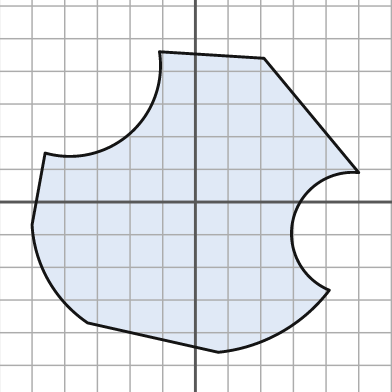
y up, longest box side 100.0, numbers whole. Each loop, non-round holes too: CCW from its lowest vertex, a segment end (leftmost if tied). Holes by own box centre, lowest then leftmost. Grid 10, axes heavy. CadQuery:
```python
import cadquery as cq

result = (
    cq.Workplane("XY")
    .moveTo(7.0, -46.0)
    .threePointArc((26.0, -40.0), (41.0, -27.0))
    .threePointArc((30.0, -5.0), (50.0, 9.0))
    .lineTo(21.0, 44.0)
    .lineTo(-11.0, 46.0)
    .threePointArc((-20.0, 21.0), (-46.0, 15.0))
    .lineTo(-50.0, -7.0)
    .threePointArc((-45.0, -24.0), (-33.0, -37.0))
    .close()
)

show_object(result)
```